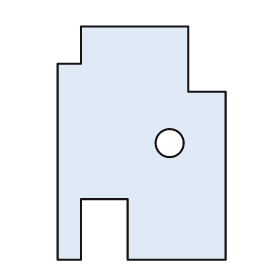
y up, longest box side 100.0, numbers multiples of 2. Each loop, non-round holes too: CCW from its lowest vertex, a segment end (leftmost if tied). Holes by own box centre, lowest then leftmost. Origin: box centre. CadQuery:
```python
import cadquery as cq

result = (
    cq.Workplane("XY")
    .moveTo(-36.0, -50.0)
    .lineTo(-26.0, -50.0)
    .lineTo(-26.0, -24.0)
    .lineTo(-6.0, -24.0)
    .lineTo(-6.0, -50.0)
    .lineTo(36.0, -50.0)
    .lineTo(36.0, 22.0)
    .lineTo(20.0, 22.0)
    .lineTo(20.0, 50.0)
    .lineTo(-26.0, 50.0)
    .lineTo(-26.0, 34.0)
    .lineTo(-36.0, 34.0)
    .close()
    .moveTo(12.0, 0.0)
    .circle(6.0)
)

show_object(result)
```